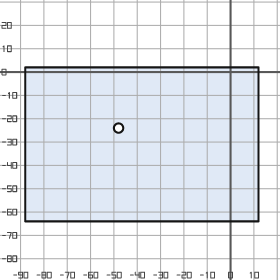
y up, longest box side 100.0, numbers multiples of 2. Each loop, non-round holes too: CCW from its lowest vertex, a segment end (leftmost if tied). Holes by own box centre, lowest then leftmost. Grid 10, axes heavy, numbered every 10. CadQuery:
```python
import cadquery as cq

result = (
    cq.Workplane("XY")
    .moveTo(-88.0, -64.0)
    .lineTo(12.0, -64.0)
    .lineTo(12.0, 2.0)
    .lineTo(-88.0, 2.0)
    .close()
    .moveTo(-48.0, -24.0)
    .circle(2.0)
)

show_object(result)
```